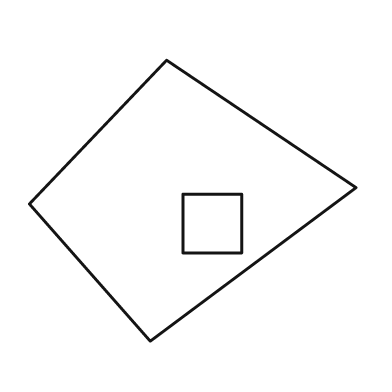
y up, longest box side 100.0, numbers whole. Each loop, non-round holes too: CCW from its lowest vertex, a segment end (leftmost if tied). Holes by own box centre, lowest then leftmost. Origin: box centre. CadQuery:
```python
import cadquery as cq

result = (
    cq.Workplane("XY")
    .moveTo(-13.0, -43.0)
    .lineTo(50.0, 4.0)
    .lineTo(-8.0, 43.0)
    .lineTo(-50.0, -1.0)
    .close()
    .moveTo(-3.0, -16.0)
    .lineTo(15.0, -16.0)
    .lineTo(15.0, 2.0)
    .lineTo(-3.0, 2.0)
    .close()
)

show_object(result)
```